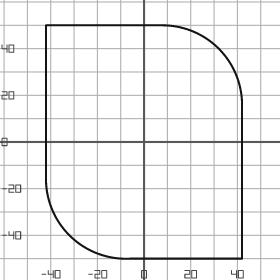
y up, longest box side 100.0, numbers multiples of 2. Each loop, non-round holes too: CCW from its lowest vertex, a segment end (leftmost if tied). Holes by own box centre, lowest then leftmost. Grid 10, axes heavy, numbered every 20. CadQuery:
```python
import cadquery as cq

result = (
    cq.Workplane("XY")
    .moveTo(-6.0, -50.0)
    .lineTo(42.0, -50.0)
    .lineTo(42.0, 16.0)
    .threePointArc((32.0, 40.0), (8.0, 50.0))
    .lineTo(-42.0, 50.0)
    .lineTo(-42.0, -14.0)
    .threePointArc((-32.0, -40.0), (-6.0, -50.0))
    .close()
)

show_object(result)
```